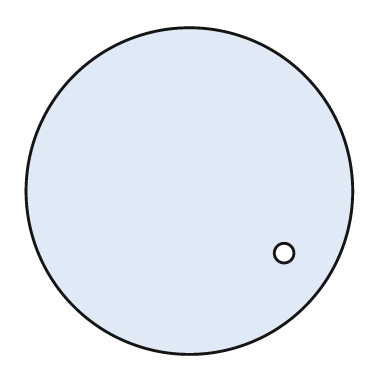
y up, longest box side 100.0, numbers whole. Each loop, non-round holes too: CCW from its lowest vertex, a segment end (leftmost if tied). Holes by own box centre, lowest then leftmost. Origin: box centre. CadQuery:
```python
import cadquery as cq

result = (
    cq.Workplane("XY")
    .moveTo(0.0, 0.0)
    .circle(50.0)
    .moveTo(29.0, -19.0)
    .circle(3.0)
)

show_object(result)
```